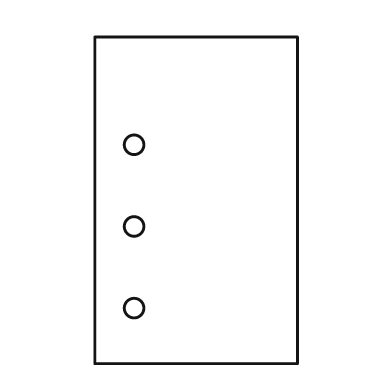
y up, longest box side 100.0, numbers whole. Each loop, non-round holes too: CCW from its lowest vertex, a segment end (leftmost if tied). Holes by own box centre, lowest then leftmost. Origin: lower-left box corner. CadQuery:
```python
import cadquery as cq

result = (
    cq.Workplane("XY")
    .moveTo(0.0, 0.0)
    .lineTo(62.0, 0.0)
    .lineTo(62.0, 100.0)
    .lineTo(0.0, 100.0)
    .close()
    .moveTo(12.0, 17.0)
    .circle(3.0)
    .moveTo(12.0, 42.0)
    .circle(3.0)
    .moveTo(12.0, 67.0)
    .circle(3.0)
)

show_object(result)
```